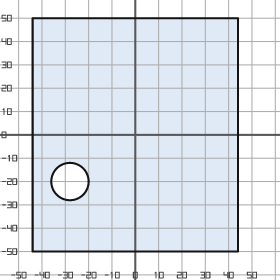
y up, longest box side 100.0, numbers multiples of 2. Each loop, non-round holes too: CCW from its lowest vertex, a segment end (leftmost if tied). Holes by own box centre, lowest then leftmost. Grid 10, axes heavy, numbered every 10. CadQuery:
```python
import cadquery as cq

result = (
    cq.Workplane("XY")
    .moveTo(-44.0, -50.0)
    .lineTo(44.0, -50.0)
    .lineTo(44.0, 50.0)
    .lineTo(-44.0, 50.0)
    .close()
    .moveTo(-28.0, -20.0)
    .circle(8.0)
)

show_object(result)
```